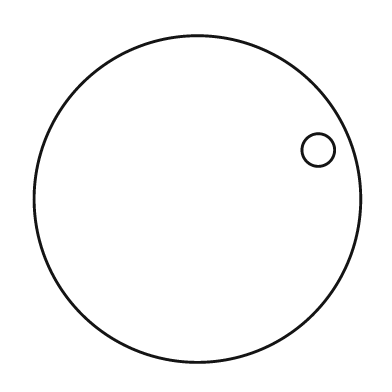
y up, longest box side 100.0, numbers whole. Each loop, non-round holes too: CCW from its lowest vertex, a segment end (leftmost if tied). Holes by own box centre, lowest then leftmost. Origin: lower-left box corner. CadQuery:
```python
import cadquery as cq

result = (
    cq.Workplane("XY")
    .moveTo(50.0, 50.0)
    .circle(50.0)
    .moveTo(87.0, 65.0)
    .circle(5.0)
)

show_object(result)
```